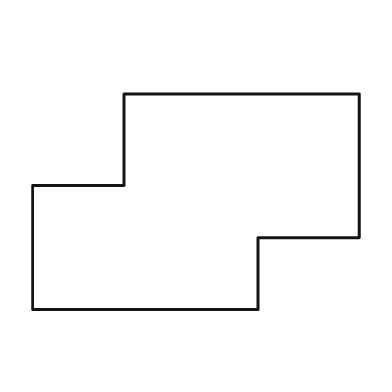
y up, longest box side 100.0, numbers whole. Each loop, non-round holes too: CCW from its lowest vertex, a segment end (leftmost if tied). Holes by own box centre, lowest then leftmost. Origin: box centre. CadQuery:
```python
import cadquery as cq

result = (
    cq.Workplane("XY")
    .moveTo(-50.0, -33.0)
    .lineTo(19.0, -33.0)
    .lineTo(19.0, -11.0)
    .lineTo(50.0, -11.0)
    .lineTo(50.0, 33.0)
    .lineTo(-22.0, 33.0)
    .lineTo(-22.0, 5.0)
    .lineTo(-50.0, 5.0)
    .close()
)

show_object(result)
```